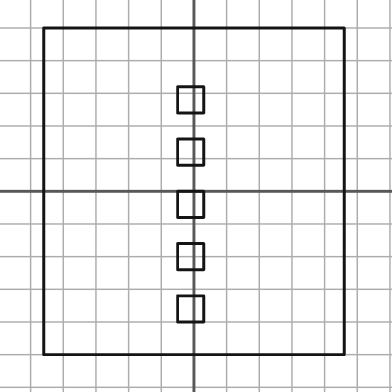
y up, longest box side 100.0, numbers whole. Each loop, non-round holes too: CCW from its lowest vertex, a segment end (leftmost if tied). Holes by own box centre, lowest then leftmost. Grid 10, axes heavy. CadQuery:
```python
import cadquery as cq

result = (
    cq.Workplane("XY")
    .moveTo(-46.0, -50.0)
    .lineTo(46.0, -50.0)
    .lineTo(46.0, 50.0)
    .lineTo(-46.0, 50.0)
    .close()
    .moveTo(-5.0, -40.0)
    .lineTo(3.0, -40.0)
    .lineTo(3.0, -32.0)
    .lineTo(-5.0, -32.0)
    .close()
    .moveTo(-5.0, -24.0)
    .lineTo(3.0, -24.0)
    .lineTo(3.0, -16.0)
    .lineTo(-5.0, -16.0)
    .close()
    .moveTo(-5.0, -8.0)
    .lineTo(3.0, -8.0)
    .lineTo(3.0, 0.0)
    .lineTo(-5.0, 0.0)
    .close()
    .moveTo(-5.0, 8.0)
    .lineTo(3.0, 8.0)
    .lineTo(3.0, 16.0)
    .lineTo(-5.0, 16.0)
    .close()
    .moveTo(-5.0, 24.0)
    .lineTo(3.0, 24.0)
    .lineTo(3.0, 32.0)
    .lineTo(-5.0, 32.0)
    .close()
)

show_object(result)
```